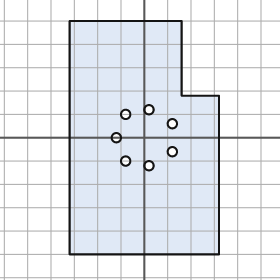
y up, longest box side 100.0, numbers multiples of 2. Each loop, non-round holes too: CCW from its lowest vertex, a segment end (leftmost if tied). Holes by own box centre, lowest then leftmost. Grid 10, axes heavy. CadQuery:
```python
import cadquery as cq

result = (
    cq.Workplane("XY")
    .moveTo(-32.0, -50.0)
    .lineTo(32.0, -50.0)
    .lineTo(32.0, 18.0)
    .lineTo(16.0, 18.0)
    .lineTo(16.0, 50.0)
    .lineTo(-32.0, 50.0)
    .close()
    .moveTo(2.0, -12.0)
    .circle(2.0)
    .moveTo(-8.0, -10.0)
    .circle(2.0)
    .moveTo(12.0, -6.0)
    .circle(2.0)
    .moveTo(-12.0, 0.0)
    .circle(2.0)
    .moveTo(12.0, 6.0)
    .circle(2.0)
    .moveTo(-8.0, 10.0)
    .circle(2.0)
    .moveTo(2.0, 12.0)
    .circle(2.0)
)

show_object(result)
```